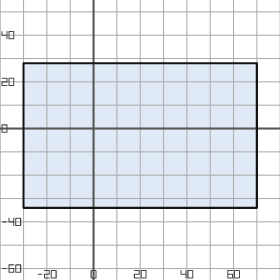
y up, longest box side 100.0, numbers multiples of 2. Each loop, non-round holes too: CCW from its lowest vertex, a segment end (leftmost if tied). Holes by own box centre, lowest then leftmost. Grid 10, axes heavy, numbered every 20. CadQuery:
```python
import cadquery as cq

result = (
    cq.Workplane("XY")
    .moveTo(-30.0, -34.0)
    .lineTo(70.0, -34.0)
    .lineTo(70.0, 28.0)
    .lineTo(-30.0, 28.0)
    .close()
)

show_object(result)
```